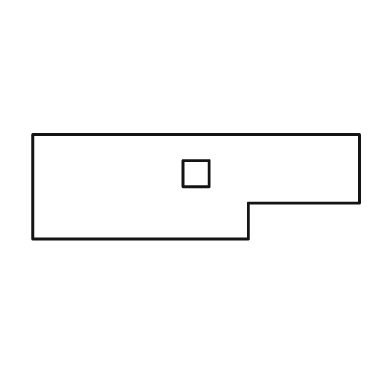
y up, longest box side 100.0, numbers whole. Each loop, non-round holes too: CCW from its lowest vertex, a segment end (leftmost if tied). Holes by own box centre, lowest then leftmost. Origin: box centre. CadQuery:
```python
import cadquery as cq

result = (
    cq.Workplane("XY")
    .moveTo(-50.0, -16.0)
    .lineTo(16.0, -16.0)
    .lineTo(16.0, -5.0)
    .lineTo(50.0, -5.0)
    .lineTo(50.0, 16.0)
    .lineTo(-50.0, 16.0)
    .close()
    .moveTo(-4.0, 0.0)
    .lineTo(4.0, 0.0)
    .lineTo(4.0, 8.0)
    .lineTo(-4.0, 8.0)
    .close()
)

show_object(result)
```